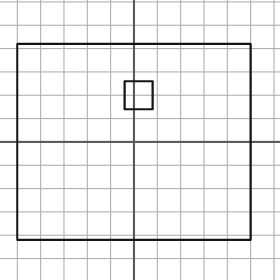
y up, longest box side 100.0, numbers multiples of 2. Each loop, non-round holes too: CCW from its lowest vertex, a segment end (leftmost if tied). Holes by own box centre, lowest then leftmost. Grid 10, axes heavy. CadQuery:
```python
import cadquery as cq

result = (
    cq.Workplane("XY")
    .moveTo(-50.0, -42.0)
    .lineTo(50.0, -42.0)
    .lineTo(50.0, 42.0)
    .lineTo(-50.0, 42.0)
    .close()
    .moveTo(-4.0, 14.0)
    .lineTo(8.0, 14.0)
    .lineTo(8.0, 26.0)
    .lineTo(-4.0, 26.0)
    .close()
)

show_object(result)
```